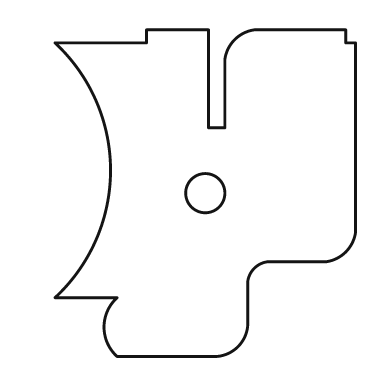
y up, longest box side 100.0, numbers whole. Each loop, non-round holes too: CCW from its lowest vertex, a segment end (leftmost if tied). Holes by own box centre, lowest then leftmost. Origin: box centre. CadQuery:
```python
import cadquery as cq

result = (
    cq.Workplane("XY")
    .moveTo(-27.0, -50.0)
    .lineTo(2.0, -50.0)
    .threePointArc((10.0, -47.0), (13.0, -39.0))
    .lineTo(13.0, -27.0)
    .threePointArc((15.0, -23.0), (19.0, -21.0))
    .lineTo(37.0, -21.0)
    .threePointArc((43.0, -18.0), (46.0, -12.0))
    .lineTo(46.0, 46.0)
    .lineTo(43.0, 46.0)
    .lineTo(43.0, 50.0)
    .lineTo(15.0, 50.0)
    .threePointArc((9.0, 47.0), (6.0, 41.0))
    .lineTo(6.0, 20.0)
    .lineTo(1.0, 20.0)
    .lineTo(1.0, 50.0)
    .lineTo(-18.0, 50.0)
    .lineTo(-18.0, 46.0)
    .lineTo(-46.0, 46.0)
    .threePointArc((-29.0, 7.0), (-46.0, -32.0))
    .lineTo(-27.0, -32.0)
    .threePointArc((-31.0, -41.0), (-27.0, -50.0))
    .close()
    .moveTo(0.0, 0.0)
    .circle(6.0)
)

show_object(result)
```